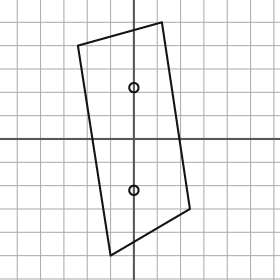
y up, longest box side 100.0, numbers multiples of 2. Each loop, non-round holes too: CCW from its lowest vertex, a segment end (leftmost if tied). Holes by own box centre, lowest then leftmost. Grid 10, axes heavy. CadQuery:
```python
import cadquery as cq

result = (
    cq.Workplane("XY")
    .moveTo(-10.0, -50.0)
    .lineTo(24.0, -30.0)
    .lineTo(12.0, 50.0)
    .lineTo(-24.0, 40.0)
    .close()
    .moveTo(0.0, -22.0)
    .circle(2.0)
    .moveTo(0.0, 22.0)
    .circle(2.0)
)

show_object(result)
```